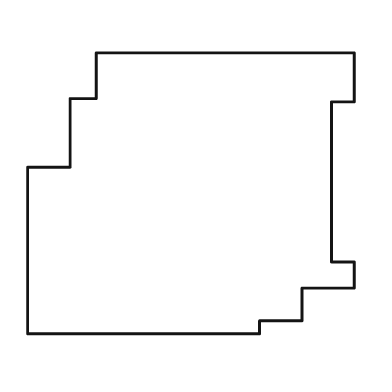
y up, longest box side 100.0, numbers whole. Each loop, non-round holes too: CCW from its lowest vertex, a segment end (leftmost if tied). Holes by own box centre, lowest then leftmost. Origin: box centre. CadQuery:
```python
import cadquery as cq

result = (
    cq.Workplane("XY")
    .moveTo(-50.0, -43.0)
    .lineTo(21.0, -43.0)
    .lineTo(21.0, -39.0)
    .lineTo(34.0, -39.0)
    .lineTo(34.0, -29.0)
    .lineTo(50.0, -29.0)
    .lineTo(50.0, -21.0)
    .lineTo(43.0, -21.0)
    .lineTo(43.0, 28.0)
    .lineTo(50.0, 28.0)
    .lineTo(50.0, 43.0)
    .lineTo(-29.0, 43.0)
    .lineTo(-29.0, 29.0)
    .lineTo(-37.0, 29.0)
    .lineTo(-37.0, 8.0)
    .lineTo(-50.0, 8.0)
    .close()
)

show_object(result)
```